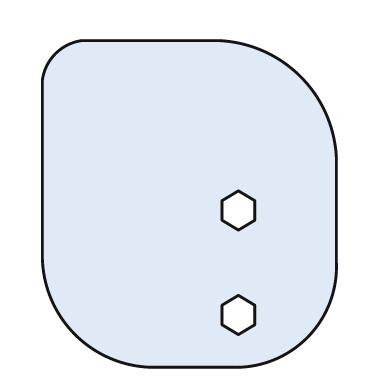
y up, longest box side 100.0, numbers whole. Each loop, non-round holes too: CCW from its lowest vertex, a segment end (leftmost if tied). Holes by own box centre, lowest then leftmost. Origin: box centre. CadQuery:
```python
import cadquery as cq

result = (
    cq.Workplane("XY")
    .moveTo(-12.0, -50.0)
    .lineTo(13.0, -50.0)
    .threePointArc((36.0, -41.0), (45.0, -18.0))
    .lineTo(45.0, 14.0)
    .threePointArc((34.0, 39.0), (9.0, 50.0))
    .lineTo(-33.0, 50.0)
    .threePointArc((-41.0, 46.0), (-45.0, 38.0))
    .lineTo(-45.0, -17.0)
    .threePointArc((-35.0, -40.0), (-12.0, -50.0))
    .close()
    .moveTo(15.0, -40.0)
    .lineTo(20.0, -37.0)
    .lineTo(20.0, -31.0)
    .lineTo(15.0, -28.0)
    .lineTo(10.0, -31.0)
    .lineTo(10.0, -37.0)
    .close()
    .moveTo(15.0, -8.0)
    .lineTo(20.0, -5.0)
    .lineTo(20.0, 1.0)
    .lineTo(15.0, 4.0)
    .lineTo(10.0, 1.0)
    .lineTo(10.0, -5.0)
    .close()
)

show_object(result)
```